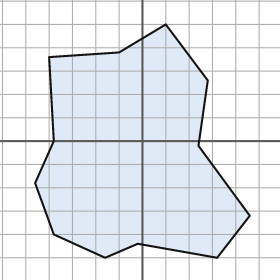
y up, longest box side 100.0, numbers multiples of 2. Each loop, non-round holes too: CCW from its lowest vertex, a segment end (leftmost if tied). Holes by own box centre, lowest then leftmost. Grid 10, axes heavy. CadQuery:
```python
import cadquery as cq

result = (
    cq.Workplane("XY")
    .moveTo(-16.0, -50.0)
    .lineTo(-2.0, -44.0)
    .lineTo(32.0, -50.0)
    .lineTo(46.0, -32.0)
    .lineTo(24.0, -2.0)
    .lineTo(28.0, 26.0)
    .lineTo(10.0, 50.0)
    .lineTo(-10.0, 38.0)
    .lineTo(-40.0, 36.0)
    .lineTo(-38.0, 0.0)
    .lineTo(-46.0, -18.0)
    .lineTo(-38.0, -40.0)
    .close()
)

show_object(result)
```